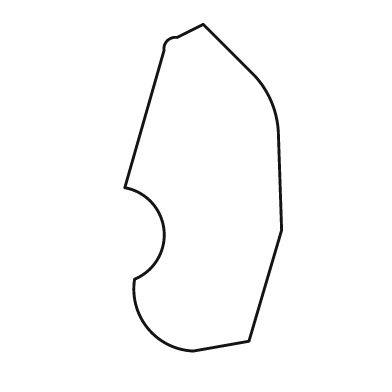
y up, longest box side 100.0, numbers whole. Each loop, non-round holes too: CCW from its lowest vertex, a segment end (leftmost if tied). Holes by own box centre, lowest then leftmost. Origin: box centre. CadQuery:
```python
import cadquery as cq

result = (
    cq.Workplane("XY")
    .moveTo(-3.0, -50.0)
    .lineTo(14.0, -47.0)
    .lineTo(24.0, -13.0)
    .lineTo(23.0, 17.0)
    .threePointArc((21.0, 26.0), (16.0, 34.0))
    .lineTo(0.0, 50.0)
    .lineTo(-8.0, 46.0)
    .threePointArc((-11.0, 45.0), (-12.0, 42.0))
    .lineTo(-24.0, 0.0)
    .threePointArc((-12.0, -13.0), (-21.0, -28.0))
    .threePointArc((-17.0, -43.0), (-3.0, -50.0))
    .close()
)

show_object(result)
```